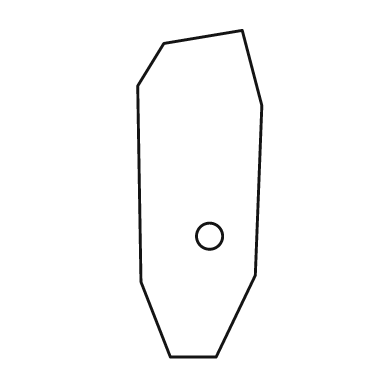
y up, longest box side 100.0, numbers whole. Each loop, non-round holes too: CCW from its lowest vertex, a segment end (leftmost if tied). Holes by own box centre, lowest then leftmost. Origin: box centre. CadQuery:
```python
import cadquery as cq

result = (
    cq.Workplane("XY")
    .moveTo(-9.0, -50.0)
    .lineTo(5.0, -50.0)
    .lineTo(17.0, -25.0)
    .lineTo(19.0, 27.0)
    .lineTo(13.0, 50.0)
    .lineTo(-11.0, 46.0)
    .lineTo(-19.0, 33.0)
    .lineTo(-18.0, -27.0)
    .close()
    .moveTo(3.0, -13.0)
    .circle(4.0)
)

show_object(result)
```